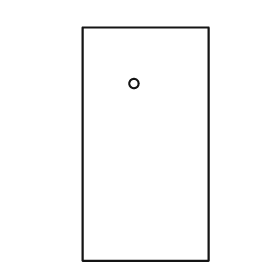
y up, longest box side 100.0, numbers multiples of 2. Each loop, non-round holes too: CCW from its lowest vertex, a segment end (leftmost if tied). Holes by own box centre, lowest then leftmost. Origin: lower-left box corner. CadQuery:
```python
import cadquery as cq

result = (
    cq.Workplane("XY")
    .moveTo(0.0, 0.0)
    .lineTo(54.0, 0.0)
    .lineTo(54.0, 100.0)
    .lineTo(0.0, 100.0)
    .close()
    .moveTo(22.0, 76.0)
    .circle(2.0)
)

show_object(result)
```